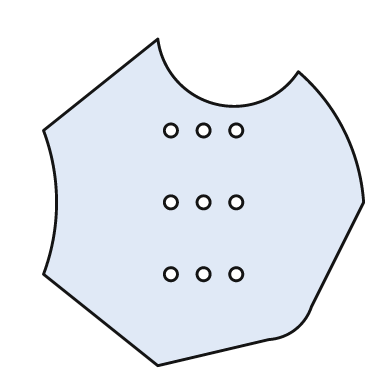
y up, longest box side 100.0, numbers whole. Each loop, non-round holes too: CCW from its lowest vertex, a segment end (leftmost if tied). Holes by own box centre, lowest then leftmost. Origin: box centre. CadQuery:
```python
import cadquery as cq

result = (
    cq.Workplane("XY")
    .moveTo(-14.0, -50.0)
    .lineTo(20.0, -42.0)
    .threePointArc((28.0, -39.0), (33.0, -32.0))
    .lineTo(49.0, 0.0)
    .threePointArc((43.0, 22.0), (29.0, 40.0))
    .threePointArc((4.0, 30.0), (-14.0, 50.0))
    .lineTo(-49.0, 22.0)
    .threePointArc((-45.0, 0.0), (-49.0, -22.0))
    .close()
    .moveTo(-10.0, -22.0)
    .circle(2.0)
    .moveTo(0.0, -22.0)
    .circle(2.0)
    .moveTo(10.0, -22.0)
    .circle(2.0)
    .moveTo(-10.0, 0.0)
    .circle(2.0)
    .moveTo(0.0, 0.0)
    .circle(2.0)
    .moveTo(10.0, 0.0)
    .circle(2.0)
    .moveTo(-10.0, 22.0)
    .circle(2.0)
    .moveTo(0.0, 22.0)
    .circle(2.0)
    .moveTo(10.0, 22.0)
    .circle(2.0)
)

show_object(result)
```